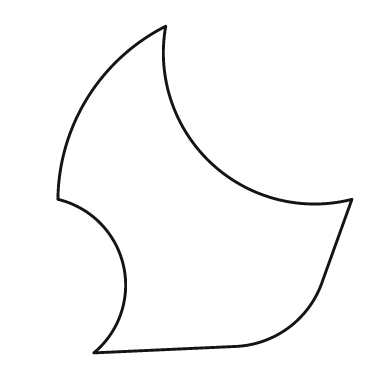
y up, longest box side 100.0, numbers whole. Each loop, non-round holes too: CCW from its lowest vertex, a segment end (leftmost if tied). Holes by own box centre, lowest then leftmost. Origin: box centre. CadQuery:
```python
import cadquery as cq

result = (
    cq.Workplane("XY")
    .moveTo(-34.0, -50.0)
    .lineTo(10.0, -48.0)
    .threePointArc((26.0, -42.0), (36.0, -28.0))
    .lineTo(45.0, -3.0)
    .threePointArc((2.0, 8.0), (-12.0, 50.0))
    .threePointArc((-36.0, 28.0), (-45.0, -3.0))
    .threePointArc((-25.0, -23.0), (-34.0, -50.0))
    .close()
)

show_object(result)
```